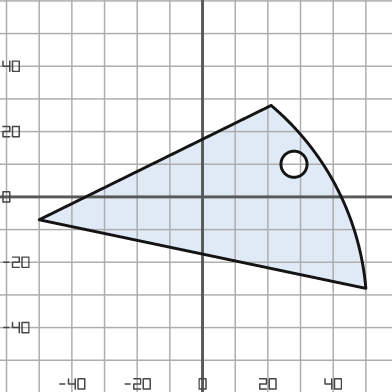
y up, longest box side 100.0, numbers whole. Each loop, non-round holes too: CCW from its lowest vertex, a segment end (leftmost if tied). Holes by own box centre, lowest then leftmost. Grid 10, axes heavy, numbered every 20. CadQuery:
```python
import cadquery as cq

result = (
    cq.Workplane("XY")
    .moveTo(50.0, -28.0)
    .threePointArc((41.0, 3.0), (21.0, 28.0))
    .lineTo(-50.0, -7.0)
    .close()
    .moveTo(28.0, 10.0)
    .circle(4.0)
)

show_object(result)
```